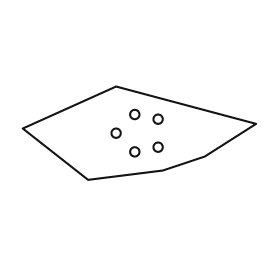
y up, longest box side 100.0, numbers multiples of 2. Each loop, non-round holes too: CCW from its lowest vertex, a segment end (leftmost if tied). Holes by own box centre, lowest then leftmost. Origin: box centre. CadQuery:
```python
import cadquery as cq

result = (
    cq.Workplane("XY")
    .moveTo(-22.0, -20.0)
    .lineTo(10.0, -16.0)
    .lineTo(28.0, -10.0)
    .lineTo(50.0, 4.0)
    .lineTo(-10.0, 20.0)
    .lineTo(-50.0, 2.0)
    .close()
    .moveTo(-2.0, -8.0)
    .circle(2.0)
    .moveTo(8.0, -6.0)
    .circle(2.0)
    .moveTo(-10.0, 0.0)
    .circle(2.0)
    .moveTo(8.0, 6.0)
    .circle(2.0)
    .moveTo(-2.0, 8.0)
    .circle(2.0)
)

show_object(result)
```